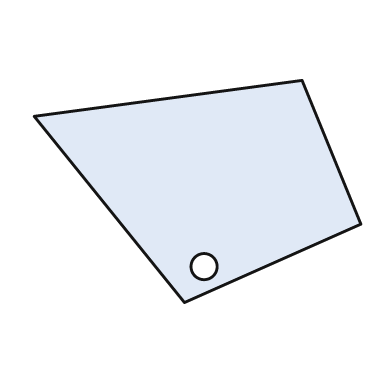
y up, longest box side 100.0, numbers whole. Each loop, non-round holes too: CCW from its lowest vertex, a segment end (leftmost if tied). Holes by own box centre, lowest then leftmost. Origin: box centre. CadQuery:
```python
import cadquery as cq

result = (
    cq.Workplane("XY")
    .moveTo(-4.0, -34.0)
    .lineTo(50.0, -10.0)
    .lineTo(32.0, 34.0)
    .lineTo(-50.0, 23.0)
    .close()
    .moveTo(2.0, -23.0)
    .circle(4.0)
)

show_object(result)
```